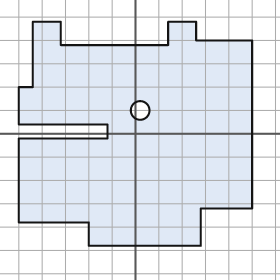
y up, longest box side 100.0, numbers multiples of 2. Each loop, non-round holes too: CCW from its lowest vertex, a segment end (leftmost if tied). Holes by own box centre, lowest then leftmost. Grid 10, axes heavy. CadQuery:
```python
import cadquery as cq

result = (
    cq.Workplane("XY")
    .moveTo(-20.0, -48.0)
    .lineTo(28.0, -48.0)
    .lineTo(28.0, -32.0)
    .lineTo(50.0, -32.0)
    .lineTo(50.0, 40.0)
    .lineTo(26.0, 40.0)
    .lineTo(26.0, 48.0)
    .lineTo(14.0, 48.0)
    .lineTo(14.0, 38.0)
    .lineTo(-32.0, 38.0)
    .lineTo(-32.0, 48.0)
    .lineTo(-44.0, 48.0)
    .lineTo(-44.0, 20.0)
    .lineTo(-50.0, 20.0)
    .lineTo(-50.0, 4.0)
    .lineTo(-12.0, 4.0)
    .lineTo(-12.0, -2.0)
    .lineTo(-50.0, -2.0)
    .lineTo(-50.0, -38.0)
    .lineTo(-20.0, -38.0)
    .close()
    .moveTo(2.0, 10.0)
    .circle(4.0)
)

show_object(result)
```